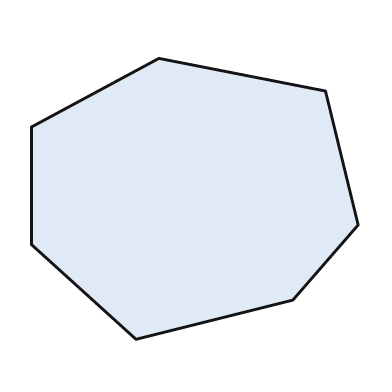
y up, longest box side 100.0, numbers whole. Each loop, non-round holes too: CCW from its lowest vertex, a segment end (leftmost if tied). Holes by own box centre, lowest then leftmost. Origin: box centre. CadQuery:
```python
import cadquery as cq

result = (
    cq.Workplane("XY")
    .moveTo(-18.0, -43.0)
    .lineTo(30.0, -31.0)
    .lineTo(50.0, -8.0)
    .lineTo(40.0, 33.0)
    .lineTo(-11.0, 43.0)
    .lineTo(-50.0, 22.0)
    .lineTo(-50.0, -14.0)
    .close()
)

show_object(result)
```